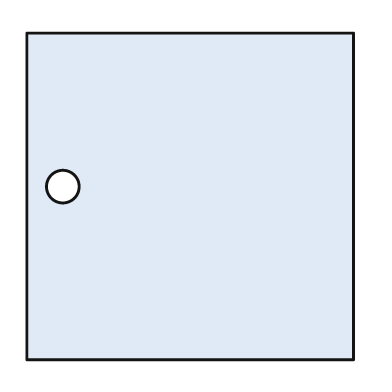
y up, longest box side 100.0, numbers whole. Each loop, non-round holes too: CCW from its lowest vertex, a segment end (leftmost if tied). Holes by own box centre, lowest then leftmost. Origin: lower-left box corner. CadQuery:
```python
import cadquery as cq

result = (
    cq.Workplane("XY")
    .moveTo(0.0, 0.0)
    .lineTo(100.0, 0.0)
    .lineTo(100.0, 100.0)
    .lineTo(0.0, 100.0)
    .close()
    .moveTo(11.0, 53.0)
    .circle(5.0)
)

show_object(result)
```